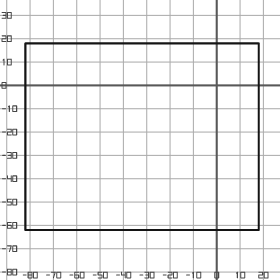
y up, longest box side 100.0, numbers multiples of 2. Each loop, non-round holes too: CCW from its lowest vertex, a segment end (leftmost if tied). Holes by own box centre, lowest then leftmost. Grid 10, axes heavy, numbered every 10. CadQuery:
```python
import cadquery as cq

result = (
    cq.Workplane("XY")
    .moveTo(-82.0, -62.0)
    .lineTo(18.0, -62.0)
    .lineTo(18.0, 18.0)
    .lineTo(-82.0, 18.0)
    .close()
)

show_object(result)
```